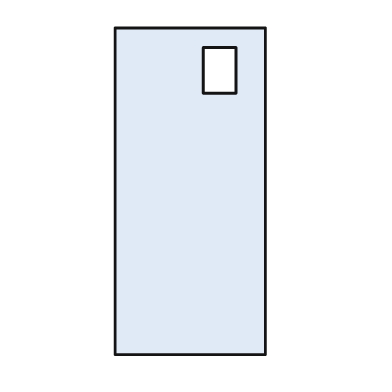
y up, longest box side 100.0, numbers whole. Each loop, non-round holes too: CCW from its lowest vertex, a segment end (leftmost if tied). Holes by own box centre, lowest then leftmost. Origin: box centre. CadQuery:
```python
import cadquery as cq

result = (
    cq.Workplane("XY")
    .moveTo(-23.0, -50.0)
    .lineTo(23.0, -50.0)
    .lineTo(23.0, 50.0)
    .lineTo(-23.0, 50.0)
    .close()
    .moveTo(4.0, 30.0)
    .lineTo(14.0, 30.0)
    .lineTo(14.0, 44.0)
    .lineTo(4.0, 44.0)
    .close()
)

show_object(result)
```